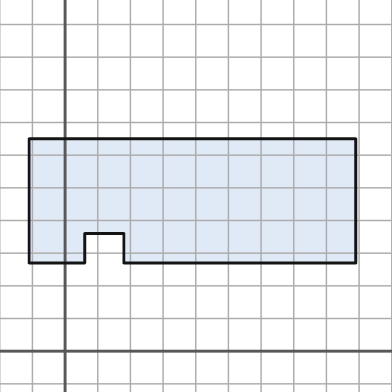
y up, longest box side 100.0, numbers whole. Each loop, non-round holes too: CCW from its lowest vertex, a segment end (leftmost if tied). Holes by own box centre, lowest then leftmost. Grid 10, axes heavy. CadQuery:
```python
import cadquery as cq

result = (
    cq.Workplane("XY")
    .moveTo(-11.0, 27.0)
    .lineTo(6.0, 27.0)
    .lineTo(6.0, 36.0)
    .lineTo(18.0, 36.0)
    .lineTo(18.0, 27.0)
    .lineTo(89.0, 27.0)
    .lineTo(89.0, 65.0)
    .lineTo(-11.0, 65.0)
    .close()
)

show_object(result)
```